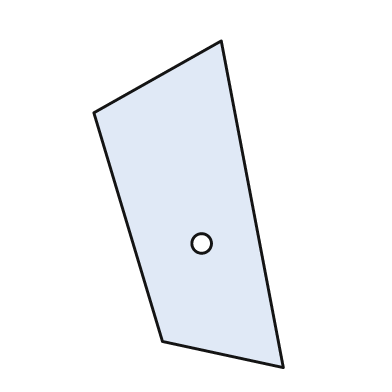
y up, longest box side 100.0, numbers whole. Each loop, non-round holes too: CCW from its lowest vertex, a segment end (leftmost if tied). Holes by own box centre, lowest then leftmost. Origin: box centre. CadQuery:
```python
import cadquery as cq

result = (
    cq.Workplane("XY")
    .moveTo(29.0, -50.0)
    .lineTo(10.0, 50.0)
    .lineTo(-29.0, 28.0)
    .lineTo(-8.0, -42.0)
    .close()
    .moveTo(4.0, -12.0)
    .circle(3.0)
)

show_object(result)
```